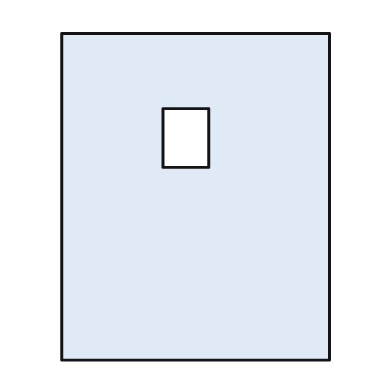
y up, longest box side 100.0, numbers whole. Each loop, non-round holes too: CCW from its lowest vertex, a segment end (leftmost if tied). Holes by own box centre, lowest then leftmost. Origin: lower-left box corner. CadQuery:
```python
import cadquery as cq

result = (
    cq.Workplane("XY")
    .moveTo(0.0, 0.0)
    .lineTo(82.0, 0.0)
    .lineTo(82.0, 100.0)
    .lineTo(0.0, 100.0)
    .close()
    .moveTo(31.0, 59.0)
    .lineTo(45.0, 59.0)
    .lineTo(45.0, 77.0)
    .lineTo(31.0, 77.0)
    .close()
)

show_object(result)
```